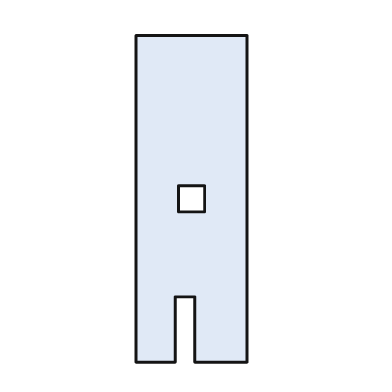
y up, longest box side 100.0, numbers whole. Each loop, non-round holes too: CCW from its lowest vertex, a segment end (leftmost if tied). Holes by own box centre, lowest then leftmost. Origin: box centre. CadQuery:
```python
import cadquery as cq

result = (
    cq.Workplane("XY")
    .moveTo(-17.0, -50.0)
    .lineTo(-5.0, -50.0)
    .lineTo(-5.0, -30.0)
    .lineTo(1.0, -30.0)
    .lineTo(1.0, -50.0)
    .lineTo(17.0, -50.0)
    .lineTo(17.0, 50.0)
    .lineTo(-17.0, 50.0)
    .close()
    .moveTo(-4.0, -4.0)
    .lineTo(4.0, -4.0)
    .lineTo(4.0, 4.0)
    .lineTo(-4.0, 4.0)
    .close()
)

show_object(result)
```